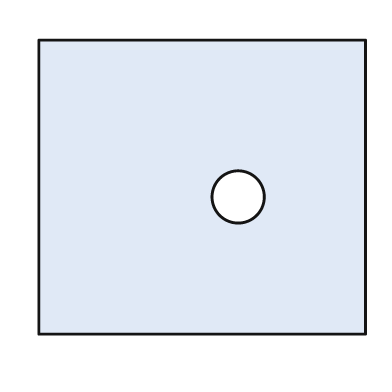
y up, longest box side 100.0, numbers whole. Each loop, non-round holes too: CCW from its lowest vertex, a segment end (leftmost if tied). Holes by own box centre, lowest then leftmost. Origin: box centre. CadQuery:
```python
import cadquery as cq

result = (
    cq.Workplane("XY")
    .moveTo(-50.0, -45.0)
    .lineTo(50.0, -45.0)
    .lineTo(50.0, 45.0)
    .lineTo(-50.0, 45.0)
    .close()
    .moveTo(11.0, -3.0)
    .circle(8.0)
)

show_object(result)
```